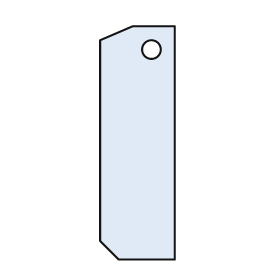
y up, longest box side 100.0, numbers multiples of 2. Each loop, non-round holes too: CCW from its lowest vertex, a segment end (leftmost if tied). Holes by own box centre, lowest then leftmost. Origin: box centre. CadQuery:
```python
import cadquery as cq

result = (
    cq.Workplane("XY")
    .moveTo(-8.0, -50.0)
    .lineTo(16.0, -50.0)
    .lineTo(16.0, 50.0)
    .lineTo(-2.0, 50.0)
    .lineTo(-16.0, 44.0)
    .lineTo(-16.0, -42.0)
    .close()
    .moveTo(6.0, 40.0)
    .circle(4.0)
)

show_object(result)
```